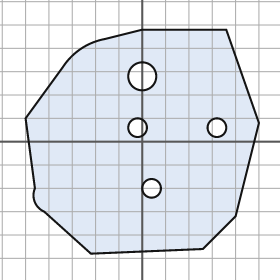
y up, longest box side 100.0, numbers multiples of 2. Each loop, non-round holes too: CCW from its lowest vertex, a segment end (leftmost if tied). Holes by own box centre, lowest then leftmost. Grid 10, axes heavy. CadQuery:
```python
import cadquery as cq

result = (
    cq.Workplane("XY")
    .moveTo(-22.0, -48.0)
    .lineTo(26.0, -46.0)
    .lineTo(40.0, -32.0)
    .lineTo(50.0, 8.0)
    .lineTo(36.0, 48.0)
    .lineTo(0.0, 48.0)
    .lineTo(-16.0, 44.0)
    .threePointArc((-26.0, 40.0), (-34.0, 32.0))
    .lineTo(-50.0, 10.0)
    .lineTo(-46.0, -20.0)
    .threePointArc((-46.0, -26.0), (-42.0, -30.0))
    .close()
    .moveTo(4.0, -20.0)
    .circle(4.0)
    .moveTo(-2.0, 6.0)
    .circle(4.0)
    .moveTo(32.0, 6.0)
    .circle(4.0)
    .moveTo(0.0, 28.0)
    .circle(6.0)
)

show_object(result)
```